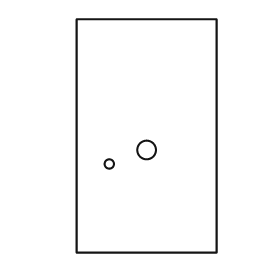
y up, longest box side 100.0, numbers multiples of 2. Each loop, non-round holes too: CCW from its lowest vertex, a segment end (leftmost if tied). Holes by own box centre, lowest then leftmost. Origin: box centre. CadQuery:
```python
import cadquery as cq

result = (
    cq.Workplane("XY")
    .moveTo(-30.0, -50.0)
    .lineTo(30.0, -50.0)
    .lineTo(30.0, 50.0)
    .lineTo(-30.0, 50.0)
    .close()
    .moveTo(-16.0, -12.0)
    .circle(2.0)
    .moveTo(0.0, -6.0)
    .circle(4.0)
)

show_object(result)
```